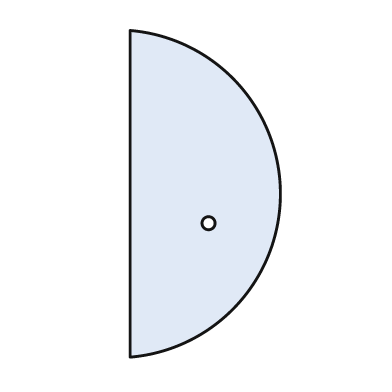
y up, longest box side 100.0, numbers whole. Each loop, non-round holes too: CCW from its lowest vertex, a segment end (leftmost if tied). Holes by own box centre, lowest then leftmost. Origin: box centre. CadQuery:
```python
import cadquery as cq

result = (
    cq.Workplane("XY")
    .moveTo(-23.0, -50.0)
    .threePointArc((23.0, 0.0), (-23.0, 50.0))
    .close()
    .moveTo(1.0, -9.0)
    .circle(2.0)
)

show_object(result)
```